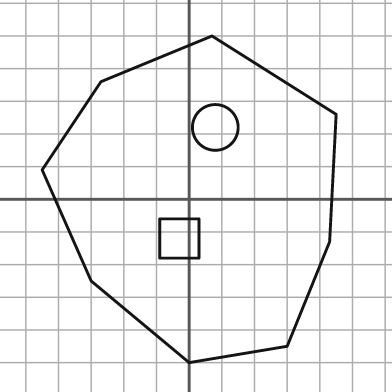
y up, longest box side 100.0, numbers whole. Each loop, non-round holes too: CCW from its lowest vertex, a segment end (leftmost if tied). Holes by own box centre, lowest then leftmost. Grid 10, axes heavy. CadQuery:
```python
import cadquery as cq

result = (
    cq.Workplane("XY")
    .moveTo(0.0, -50.0)
    .lineTo(30.0, -45.0)
    .lineTo(43.0, -13.0)
    .lineTo(45.0, 26.0)
    .lineTo(7.0, 50.0)
    .lineTo(-27.0, 36.0)
    .lineTo(-45.0, 9.0)
    .lineTo(-30.0, -25.0)
    .close()
    .moveTo(-9.0, -18.0)
    .lineTo(3.0, -18.0)
    .lineTo(3.0, -6.0)
    .lineTo(-9.0, -6.0)
    .close()
    .moveTo(8.0, 22.0)
    .circle(7.0)
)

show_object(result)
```